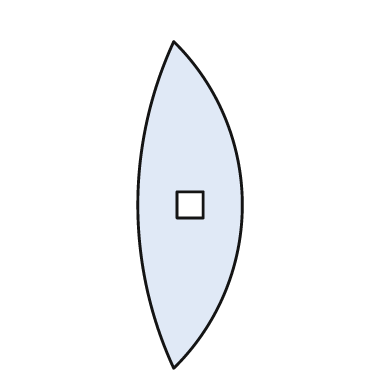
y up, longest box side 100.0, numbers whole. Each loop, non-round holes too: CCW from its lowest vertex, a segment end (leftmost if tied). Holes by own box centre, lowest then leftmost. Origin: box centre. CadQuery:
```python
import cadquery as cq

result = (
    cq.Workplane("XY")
    .moveTo(-5.0, -50.0)
    .threePointArc((16.0, 0.0), (-5.0, 50.0))
    .threePointArc((-16.0, 0.0), (-5.0, -50.0))
    .close()
    .moveTo(-4.0, -4.0)
    .lineTo(4.0, -4.0)
    .lineTo(4.0, 4.0)
    .lineTo(-4.0, 4.0)
    .close()
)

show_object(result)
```